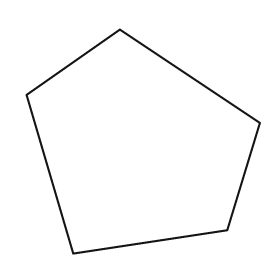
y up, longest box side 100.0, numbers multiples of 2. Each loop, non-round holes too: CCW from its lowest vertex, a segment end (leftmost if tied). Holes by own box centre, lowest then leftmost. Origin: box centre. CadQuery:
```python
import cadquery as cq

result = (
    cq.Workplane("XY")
    .moveTo(-30.0, -48.0)
    .lineTo(36.0, -38.0)
    .lineTo(50.0, 8.0)
    .lineTo(-10.0, 48.0)
    .lineTo(-50.0, 20.0)
    .close()
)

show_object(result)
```